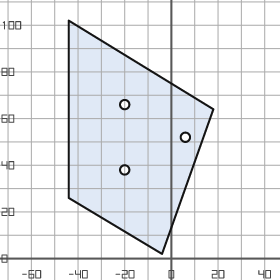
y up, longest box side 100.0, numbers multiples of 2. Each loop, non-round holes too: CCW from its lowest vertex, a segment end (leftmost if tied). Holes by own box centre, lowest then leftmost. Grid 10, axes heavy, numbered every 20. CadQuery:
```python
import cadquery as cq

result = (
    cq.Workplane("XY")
    .moveTo(-4.0, 2.0)
    .lineTo(18.0, 64.0)
    .lineTo(-44.0, 102.0)
    .lineTo(-44.0, 26.0)
    .close()
    .moveTo(-20.0, 38.0)
    .circle(2.0)
    .moveTo(6.0, 52.0)
    .circle(2.0)
    .moveTo(-20.0, 66.0)
    .circle(2.0)
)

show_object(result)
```